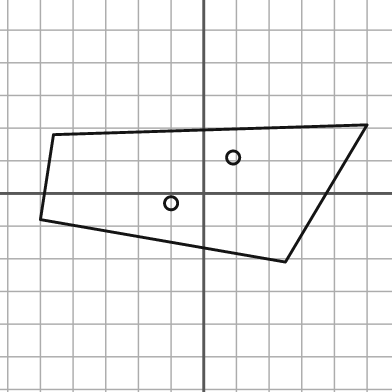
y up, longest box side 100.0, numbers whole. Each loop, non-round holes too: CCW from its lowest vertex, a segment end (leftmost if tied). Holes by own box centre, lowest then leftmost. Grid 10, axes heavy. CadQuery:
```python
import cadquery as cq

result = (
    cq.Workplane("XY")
    .moveTo(25.0, -21.0)
    .lineTo(50.0, 21.0)
    .lineTo(-46.0, 18.0)
    .lineTo(-50.0, -8.0)
    .close()
    .moveTo(-10.0, -3.0)
    .circle(2.0)
    .moveTo(9.0, 11.0)
    .circle(2.0)
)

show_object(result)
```